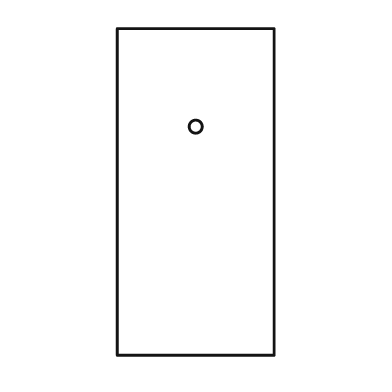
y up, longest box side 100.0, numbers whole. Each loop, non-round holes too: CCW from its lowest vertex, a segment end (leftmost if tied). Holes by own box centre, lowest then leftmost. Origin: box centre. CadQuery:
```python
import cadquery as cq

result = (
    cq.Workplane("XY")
    .moveTo(-24.0, -50.0)
    .lineTo(24.0, -50.0)
    .lineTo(24.0, 50.0)
    .lineTo(-24.0, 50.0)
    .close()
    .moveTo(0.0, 20.0)
    .circle(2.0)
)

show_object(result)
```